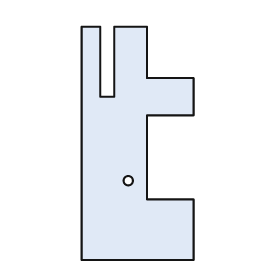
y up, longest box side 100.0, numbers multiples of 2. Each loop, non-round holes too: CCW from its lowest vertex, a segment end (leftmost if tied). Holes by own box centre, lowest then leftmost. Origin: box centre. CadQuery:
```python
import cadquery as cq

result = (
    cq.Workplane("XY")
    .moveTo(-24.0, -50.0)
    .lineTo(24.0, -50.0)
    .lineTo(24.0, -24.0)
    .lineTo(4.0, -24.0)
    .lineTo(4.0, 12.0)
    .lineTo(24.0, 12.0)
    .lineTo(24.0, 28.0)
    .lineTo(4.0, 28.0)
    .lineTo(4.0, 50.0)
    .lineTo(-10.0, 50.0)
    .lineTo(-10.0, 20.0)
    .lineTo(-16.0, 20.0)
    .lineTo(-16.0, 50.0)
    .lineTo(-24.0, 50.0)
    .close()
    .moveTo(-4.0, -16.0)
    .circle(2.0)
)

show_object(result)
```